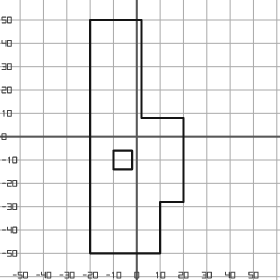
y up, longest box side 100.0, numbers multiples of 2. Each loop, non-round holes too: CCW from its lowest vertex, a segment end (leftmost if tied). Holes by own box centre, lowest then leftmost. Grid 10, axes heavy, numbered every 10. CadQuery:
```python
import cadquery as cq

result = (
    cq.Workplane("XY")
    .moveTo(-20.0, -50.0)
    .lineTo(10.0, -50.0)
    .lineTo(10.0, -28.0)
    .lineTo(20.0, -28.0)
    .lineTo(20.0, 8.0)
    .lineTo(2.0, 8.0)
    .lineTo(2.0, 50.0)
    .lineTo(-20.0, 50.0)
    .close()
    .moveTo(-10.0, -14.0)
    .lineTo(-2.0, -14.0)
    .lineTo(-2.0, -6.0)
    .lineTo(-10.0, -6.0)
    .close()
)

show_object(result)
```